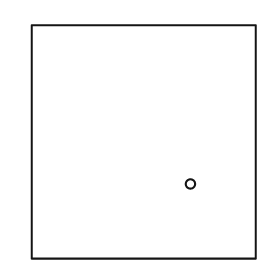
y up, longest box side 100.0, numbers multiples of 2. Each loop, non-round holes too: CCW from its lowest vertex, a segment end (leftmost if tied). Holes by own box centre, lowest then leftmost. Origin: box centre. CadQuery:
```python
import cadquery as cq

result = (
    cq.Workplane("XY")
    .moveTo(-48.0, -50.0)
    .lineTo(48.0, -50.0)
    .lineTo(48.0, 50.0)
    .lineTo(-48.0, 50.0)
    .close()
    .moveTo(20.0, -18.0)
    .circle(2.0)
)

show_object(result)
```